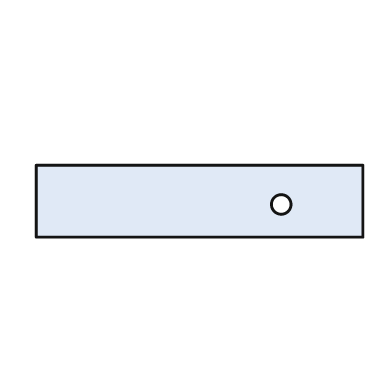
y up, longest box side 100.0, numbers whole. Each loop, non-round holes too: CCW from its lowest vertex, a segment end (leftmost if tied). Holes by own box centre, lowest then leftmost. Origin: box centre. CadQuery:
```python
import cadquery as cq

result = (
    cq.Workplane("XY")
    .moveTo(-50.0, -11.0)
    .lineTo(50.0, -11.0)
    .lineTo(50.0, 11.0)
    .lineTo(-50.0, 11.0)
    .close()
    .moveTo(25.0, -1.0)
    .circle(3.0)
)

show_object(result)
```